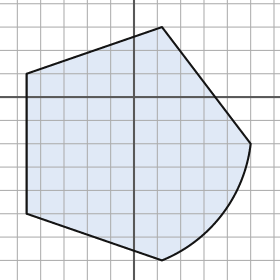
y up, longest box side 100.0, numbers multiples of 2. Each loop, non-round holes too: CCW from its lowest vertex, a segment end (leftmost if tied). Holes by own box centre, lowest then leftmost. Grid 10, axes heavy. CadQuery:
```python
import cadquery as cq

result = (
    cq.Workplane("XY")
    .moveTo(12.0, -70.0)
    .threePointArc((38.0, -50.0), (50.0, -20.0))
    .lineTo(12.0, 30.0)
    .lineTo(-46.0, 10.0)
    .lineTo(-46.0, -50.0)
    .close()
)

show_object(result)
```